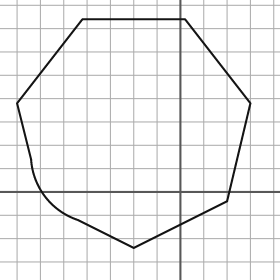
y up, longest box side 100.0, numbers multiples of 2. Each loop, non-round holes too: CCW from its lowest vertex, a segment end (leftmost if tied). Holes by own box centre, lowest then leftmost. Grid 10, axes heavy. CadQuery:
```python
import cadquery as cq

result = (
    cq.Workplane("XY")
    .moveTo(-20.0, -24.0)
    .lineTo(20.0, -4.0)
    .lineTo(30.0, 38.0)
    .lineTo(2.0, 74.0)
    .lineTo(-42.0, 74.0)
    .lineTo(-70.0, 38.0)
    .lineTo(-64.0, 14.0)
    .threePointArc((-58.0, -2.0), (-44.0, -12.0))
    .close()
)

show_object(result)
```